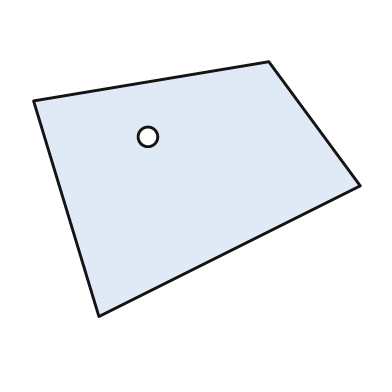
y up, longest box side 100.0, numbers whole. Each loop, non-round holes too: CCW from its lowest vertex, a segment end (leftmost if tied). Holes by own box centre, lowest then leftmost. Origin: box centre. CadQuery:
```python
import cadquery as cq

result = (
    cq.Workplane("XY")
    .moveTo(-30.0, -39.0)
    .lineTo(50.0, 1.0)
    .lineTo(22.0, 39.0)
    .lineTo(-50.0, 27.0)
    .close()
    .moveTo(-15.0, 16.0)
    .circle(3.0)
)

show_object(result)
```